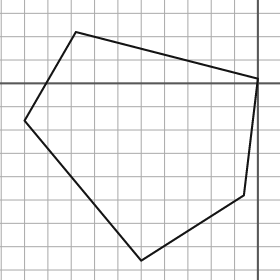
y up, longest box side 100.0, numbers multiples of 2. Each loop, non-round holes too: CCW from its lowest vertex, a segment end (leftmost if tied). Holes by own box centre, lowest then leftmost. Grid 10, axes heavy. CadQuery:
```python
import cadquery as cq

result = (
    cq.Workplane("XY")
    .moveTo(-50.0, -76.0)
    .lineTo(-6.0, -48.0)
    .lineTo(0.0, 2.0)
    .lineTo(-78.0, 22.0)
    .lineTo(-100.0, -16.0)
    .close()
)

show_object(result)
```